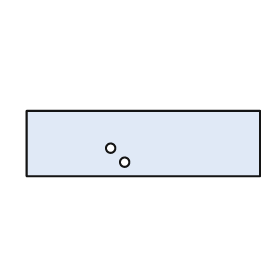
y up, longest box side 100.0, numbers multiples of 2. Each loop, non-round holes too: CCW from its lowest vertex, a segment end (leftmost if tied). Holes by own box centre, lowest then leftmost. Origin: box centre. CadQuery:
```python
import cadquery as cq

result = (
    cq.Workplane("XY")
    .moveTo(-50.0, -14.0)
    .lineTo(50.0, -14.0)
    .lineTo(50.0, 14.0)
    .lineTo(-50.0, 14.0)
    .close()
    .moveTo(-8.0, -8.0)
    .circle(2.0)
    .moveTo(-14.0, -2.0)
    .circle(2.0)
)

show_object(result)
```